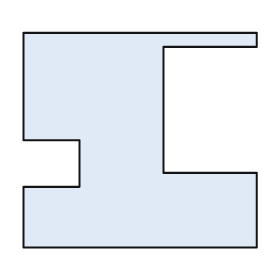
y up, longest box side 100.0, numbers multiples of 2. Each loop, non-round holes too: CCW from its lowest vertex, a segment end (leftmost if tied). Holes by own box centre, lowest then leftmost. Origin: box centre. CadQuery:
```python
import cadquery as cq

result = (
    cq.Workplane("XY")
    .moveTo(-50.0, -46.0)
    .lineTo(50.0, -46.0)
    .lineTo(50.0, -14.0)
    .lineTo(10.0, -14.0)
    .lineTo(10.0, 40.0)
    .lineTo(50.0, 40.0)
    .lineTo(50.0, 46.0)
    .lineTo(-50.0, 46.0)
    .lineTo(-50.0, 0.0)
    .lineTo(-26.0, 0.0)
    .lineTo(-26.0, -20.0)
    .lineTo(-50.0, -20.0)
    .close()
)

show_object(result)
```